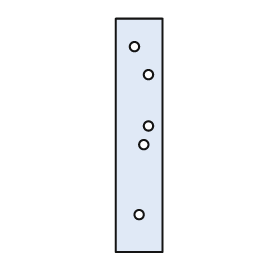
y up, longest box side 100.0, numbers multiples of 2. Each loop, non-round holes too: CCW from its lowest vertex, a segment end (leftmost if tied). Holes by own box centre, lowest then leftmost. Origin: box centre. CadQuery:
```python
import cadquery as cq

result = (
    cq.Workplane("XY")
    .moveTo(-10.0, -50.0)
    .lineTo(10.0, -50.0)
    .lineTo(10.0, 50.0)
    .lineTo(-10.0, 50.0)
    .close()
    .moveTo(0.0, -34.0)
    .circle(2.0)
    .moveTo(2.0, -4.0)
    .circle(2.0)
    .moveTo(4.0, 4.0)
    .circle(2.0)
    .moveTo(4.0, 26.0)
    .circle(2.0)
    .moveTo(-2.0, 38.0)
    .circle(2.0)
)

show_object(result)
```